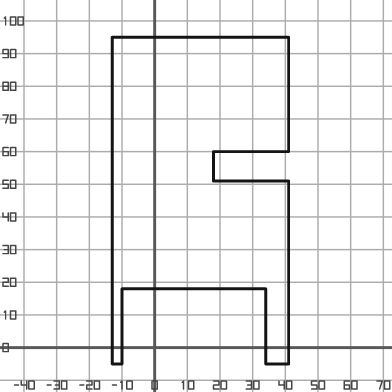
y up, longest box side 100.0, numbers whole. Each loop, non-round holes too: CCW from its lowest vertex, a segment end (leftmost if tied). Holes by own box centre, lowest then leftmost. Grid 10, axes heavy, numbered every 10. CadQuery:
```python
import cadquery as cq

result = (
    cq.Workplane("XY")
    .moveTo(-13.0, -5.0)
    .lineTo(-10.0, -5.0)
    .lineTo(-10.0, 18.0)
    .lineTo(34.0, 18.0)
    .lineTo(34.0, -5.0)
    .lineTo(41.0, -5.0)
    .lineTo(41.0, 51.0)
    .lineTo(18.0, 51.0)
    .lineTo(18.0, 60.0)
    .lineTo(41.0, 60.0)
    .lineTo(41.0, 95.0)
    .lineTo(-13.0, 95.0)
    .close()
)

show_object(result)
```